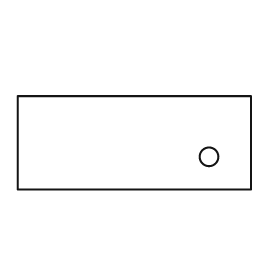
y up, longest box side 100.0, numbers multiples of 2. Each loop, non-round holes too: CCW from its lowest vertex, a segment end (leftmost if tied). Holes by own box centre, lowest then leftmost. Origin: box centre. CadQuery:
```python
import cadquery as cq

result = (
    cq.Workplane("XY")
    .moveTo(-50.0, -20.0)
    .lineTo(50.0, -20.0)
    .lineTo(50.0, 20.0)
    .lineTo(-50.0, 20.0)
    .close()
    .moveTo(32.0, -6.0)
    .circle(4.0)
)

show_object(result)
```